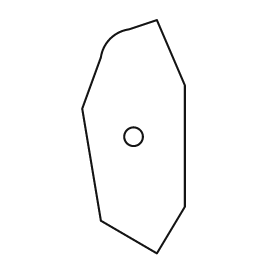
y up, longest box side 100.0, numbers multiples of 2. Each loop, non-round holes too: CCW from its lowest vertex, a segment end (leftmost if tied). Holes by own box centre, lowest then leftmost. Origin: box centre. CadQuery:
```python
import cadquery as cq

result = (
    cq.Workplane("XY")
    .moveTo(10.0, -50.0)
    .lineTo(22.0, -30.0)
    .lineTo(22.0, 22.0)
    .lineTo(10.0, 50.0)
    .lineTo(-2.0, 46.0)
    .threePointArc((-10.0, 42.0), (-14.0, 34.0))
    .lineTo(-22.0, 12.0)
    .lineTo(-14.0, -36.0)
    .close()
    .moveTo(0.0, 0.0)
    .circle(4.0)
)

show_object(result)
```